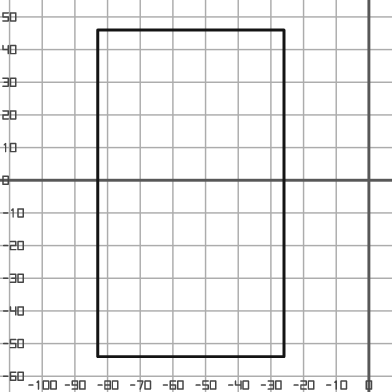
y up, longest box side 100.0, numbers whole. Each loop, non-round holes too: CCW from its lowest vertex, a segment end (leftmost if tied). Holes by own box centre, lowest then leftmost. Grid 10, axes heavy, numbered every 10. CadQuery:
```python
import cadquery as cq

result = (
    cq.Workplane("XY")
    .moveTo(-83.0, -54.0)
    .lineTo(-26.0, -54.0)
    .lineTo(-26.0, 46.0)
    .lineTo(-83.0, 46.0)
    .close()
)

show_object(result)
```